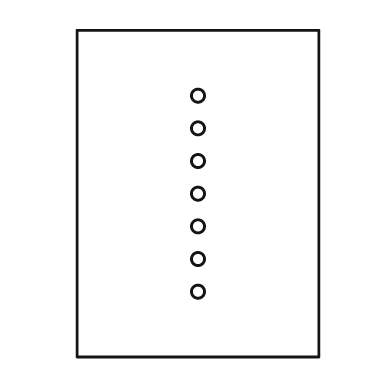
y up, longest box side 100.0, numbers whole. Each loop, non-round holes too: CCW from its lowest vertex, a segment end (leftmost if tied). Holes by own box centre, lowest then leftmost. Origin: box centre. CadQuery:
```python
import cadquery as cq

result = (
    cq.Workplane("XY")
    .moveTo(-37.0, -50.0)
    .lineTo(37.0, -50.0)
    .lineTo(37.0, 50.0)
    .lineTo(-37.0, 50.0)
    .close()
    .moveTo(0.0, -30.0)
    .circle(2.0)
    .moveTo(0.0, -20.0)
    .circle(2.0)
    .moveTo(0.0, -10.0)
    .circle(2.0)
    .moveTo(0.0, 0.0)
    .circle(2.0)
    .moveTo(0.0, 10.0)
    .circle(2.0)
    .moveTo(0.0, 20.0)
    .circle(2.0)
    .moveTo(0.0, 30.0)
    .circle(2.0)
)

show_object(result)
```